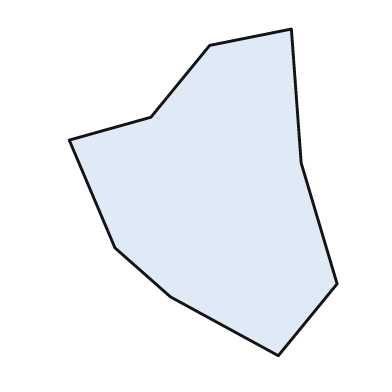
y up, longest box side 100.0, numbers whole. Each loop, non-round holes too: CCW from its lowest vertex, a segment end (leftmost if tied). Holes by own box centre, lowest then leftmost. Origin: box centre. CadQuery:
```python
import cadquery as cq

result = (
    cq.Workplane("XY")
    .moveTo(23.0, -50.0)
    .lineTo(41.0, -28.0)
    .lineTo(30.0, 9.0)
    .lineTo(27.0, 50.0)
    .lineTo(2.0, 45.0)
    .lineTo(-16.0, 23.0)
    .lineTo(-41.0, 16.0)
    .lineTo(-27.0, -17.0)
    .lineTo(-10.0, -32.0)
    .close()
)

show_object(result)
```